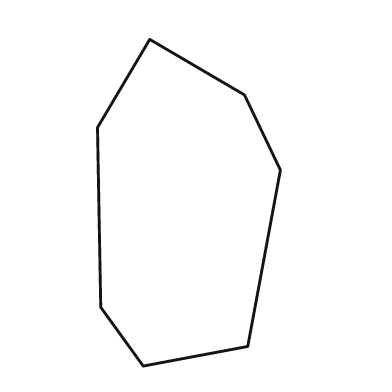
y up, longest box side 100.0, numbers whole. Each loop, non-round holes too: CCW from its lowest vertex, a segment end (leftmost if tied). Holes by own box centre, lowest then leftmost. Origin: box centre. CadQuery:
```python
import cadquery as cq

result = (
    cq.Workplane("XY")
    .moveTo(-14.0, -50.0)
    .lineTo(18.0, -44.0)
    .lineTo(28.0, 10.0)
    .lineTo(17.0, 33.0)
    .lineTo(-12.0, 50.0)
    .lineTo(-28.0, 23.0)
    .lineTo(-27.0, -32.0)
    .close()
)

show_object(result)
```